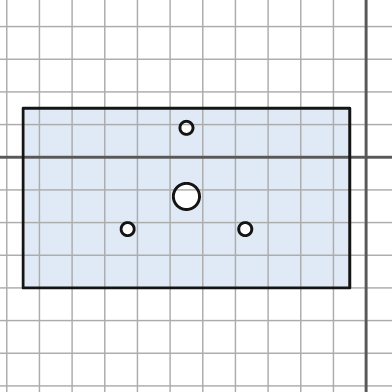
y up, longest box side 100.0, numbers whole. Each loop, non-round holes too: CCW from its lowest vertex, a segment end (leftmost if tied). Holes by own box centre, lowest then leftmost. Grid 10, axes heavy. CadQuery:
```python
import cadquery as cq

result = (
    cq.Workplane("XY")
    .moveTo(-105.0, -40.0)
    .lineTo(-5.0, -40.0)
    .lineTo(-5.0, 15.0)
    .lineTo(-105.0, 15.0)
    .close()
    .moveTo(-73.0, -22.0)
    .circle(2.0)
    .moveTo(-37.0, -22.0)
    .circle(2.0)
    .moveTo(-55.0, -12.0)
    .circle(4.0)
    .moveTo(-55.0, 9.0)
    .circle(2.0)
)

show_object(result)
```